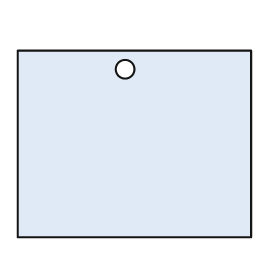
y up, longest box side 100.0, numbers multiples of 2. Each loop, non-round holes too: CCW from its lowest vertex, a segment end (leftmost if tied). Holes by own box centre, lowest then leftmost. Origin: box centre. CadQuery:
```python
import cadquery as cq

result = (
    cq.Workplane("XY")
    .moveTo(-50.0, -40.0)
    .lineTo(50.0, -40.0)
    .lineTo(50.0, 40.0)
    .lineTo(-50.0, 40.0)
    .close()
    .moveTo(-4.0, 32.0)
    .circle(4.0)
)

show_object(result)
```